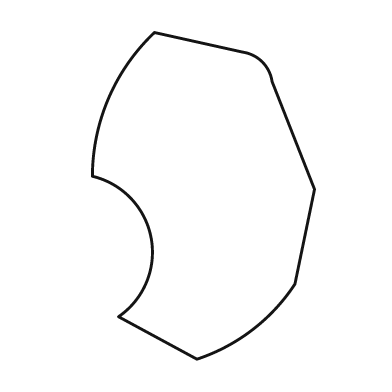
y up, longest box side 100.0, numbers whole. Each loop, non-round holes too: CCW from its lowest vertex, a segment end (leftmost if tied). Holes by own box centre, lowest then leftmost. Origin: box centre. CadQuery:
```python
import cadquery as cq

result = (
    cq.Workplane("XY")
    .moveTo(-2.0, -50.0)
    .threePointArc((15.0, -41.0), (28.0, -27.0))
    .lineTo(34.0, 2.0)
    .lineTo(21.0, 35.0)
    .threePointArc((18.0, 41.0), (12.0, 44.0))
    .lineTo(-15.0, 50.0)
    .threePointArc((-29.0, 30.0), (-34.0, 6.0))
    .threePointArc((-16.0, -13.0), (-26.0, -37.0))
    .close()
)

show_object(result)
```